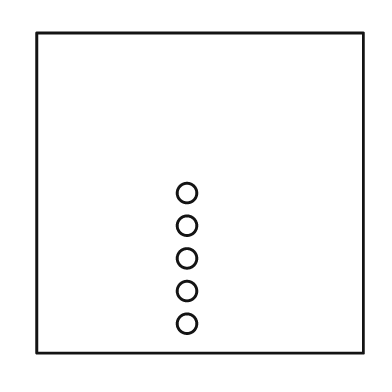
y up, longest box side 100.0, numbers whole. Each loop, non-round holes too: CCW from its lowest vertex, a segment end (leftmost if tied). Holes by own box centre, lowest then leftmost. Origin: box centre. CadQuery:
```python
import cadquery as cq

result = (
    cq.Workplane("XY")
    .moveTo(-50.0, -49.0)
    .lineTo(50.0, -49.0)
    .lineTo(50.0, 49.0)
    .lineTo(-50.0, 49.0)
    .close()
    .moveTo(-4.0, -40.0)
    .circle(3.0)
    .moveTo(-4.0, -30.0)
    .circle(3.0)
    .moveTo(-4.0, -20.0)
    .circle(3.0)
    .moveTo(-4.0, -10.0)
    .circle(3.0)
    .moveTo(-4.0, 0.0)
    .circle(3.0)
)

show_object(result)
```